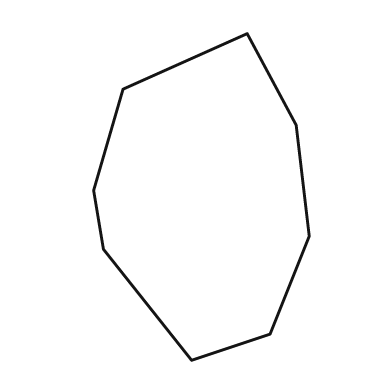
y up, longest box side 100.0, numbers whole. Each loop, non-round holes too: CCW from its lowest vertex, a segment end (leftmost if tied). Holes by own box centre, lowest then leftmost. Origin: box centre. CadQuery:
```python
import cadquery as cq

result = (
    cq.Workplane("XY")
    .moveTo(-3.0, -50.0)
    .lineTo(21.0, -42.0)
    .lineTo(33.0, -12.0)
    .lineTo(29.0, 22.0)
    .lineTo(14.0, 50.0)
    .lineTo(-24.0, 33.0)
    .lineTo(-33.0, 2.0)
    .lineTo(-30.0, -16.0)
    .close()
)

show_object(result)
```